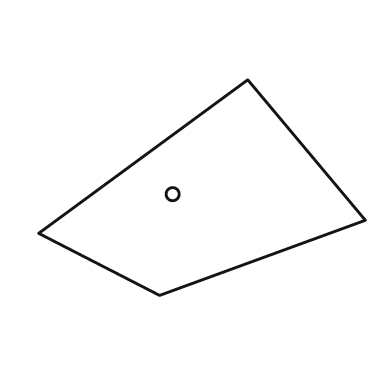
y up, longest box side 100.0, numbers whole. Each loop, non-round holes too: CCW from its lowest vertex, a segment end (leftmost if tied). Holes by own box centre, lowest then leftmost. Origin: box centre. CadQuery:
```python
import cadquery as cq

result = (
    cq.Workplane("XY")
    .moveTo(-13.0, -33.0)
    .lineTo(50.0, -10.0)
    .lineTo(14.0, 33.0)
    .lineTo(-50.0, -14.0)
    .close()
    .moveTo(-9.0, -2.0)
    .circle(2.0)
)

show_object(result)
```